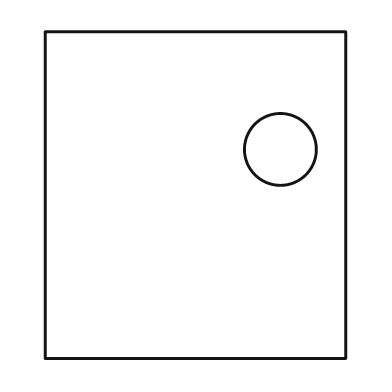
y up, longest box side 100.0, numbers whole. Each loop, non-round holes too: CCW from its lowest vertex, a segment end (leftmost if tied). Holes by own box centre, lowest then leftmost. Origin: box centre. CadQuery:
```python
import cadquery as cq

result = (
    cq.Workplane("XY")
    .moveTo(-46.0, -50.0)
    .lineTo(46.0, -50.0)
    .lineTo(46.0, 50.0)
    .lineTo(-46.0, 50.0)
    .close()
    .moveTo(26.0, 14.0)
    .circle(11.0)
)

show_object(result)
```